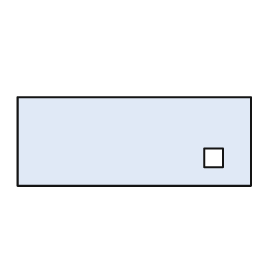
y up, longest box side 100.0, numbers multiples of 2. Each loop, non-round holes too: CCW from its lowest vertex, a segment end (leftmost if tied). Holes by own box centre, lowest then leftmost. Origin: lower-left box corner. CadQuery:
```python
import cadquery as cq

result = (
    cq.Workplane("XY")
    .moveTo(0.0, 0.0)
    .lineTo(100.0, 0.0)
    .lineTo(100.0, 38.0)
    .lineTo(0.0, 38.0)
    .close()
    .moveTo(80.0, 8.0)
    .lineTo(88.0, 8.0)
    .lineTo(88.0, 16.0)
    .lineTo(80.0, 16.0)
    .close()
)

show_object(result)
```